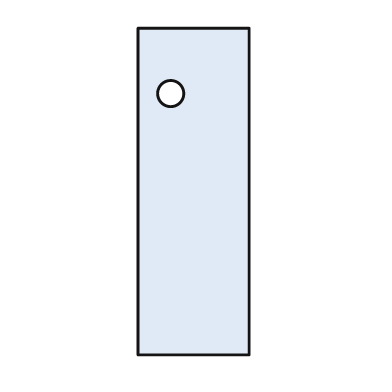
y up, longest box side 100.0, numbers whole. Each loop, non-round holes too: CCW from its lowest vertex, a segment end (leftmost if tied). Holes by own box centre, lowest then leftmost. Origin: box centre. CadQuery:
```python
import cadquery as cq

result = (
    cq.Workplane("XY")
    .moveTo(-17.0, -50.0)
    .lineTo(17.0, -50.0)
    .lineTo(17.0, 50.0)
    .lineTo(-17.0, 50.0)
    .close()
    .moveTo(-7.0, 30.0)
    .circle(4.0)
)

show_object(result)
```